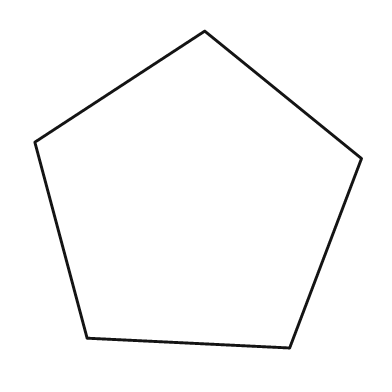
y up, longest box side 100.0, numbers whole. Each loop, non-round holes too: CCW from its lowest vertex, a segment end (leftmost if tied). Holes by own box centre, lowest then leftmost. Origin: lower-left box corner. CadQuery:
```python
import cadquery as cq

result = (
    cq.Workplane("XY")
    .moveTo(78.0, 0.0)
    .lineTo(100.0, 58.0)
    .lineTo(52.0, 97.0)
    .lineTo(0.0, 63.0)
    .lineTo(16.0, 3.0)
    .close()
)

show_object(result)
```